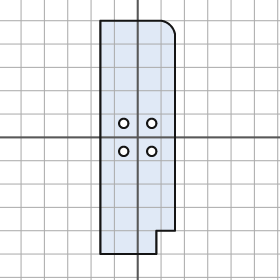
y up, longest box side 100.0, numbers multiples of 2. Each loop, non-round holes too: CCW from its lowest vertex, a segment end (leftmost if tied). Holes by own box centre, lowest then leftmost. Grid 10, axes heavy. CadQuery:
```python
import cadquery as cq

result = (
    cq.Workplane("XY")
    .moveTo(-16.0, -50.0)
    .lineTo(8.0, -50.0)
    .lineTo(8.0, -40.0)
    .lineTo(16.0, -40.0)
    .lineTo(16.0, 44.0)
    .threePointArc((14.0, 48.0), (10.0, 50.0))
    .lineTo(-16.0, 50.0)
    .close()
    .moveTo(-6.0, -6.0)
    .circle(2.0)
    .moveTo(6.0, -6.0)
    .circle(2.0)
    .moveTo(-6.0, 6.0)
    .circle(2.0)
    .moveTo(6.0, 6.0)
    .circle(2.0)
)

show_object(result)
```